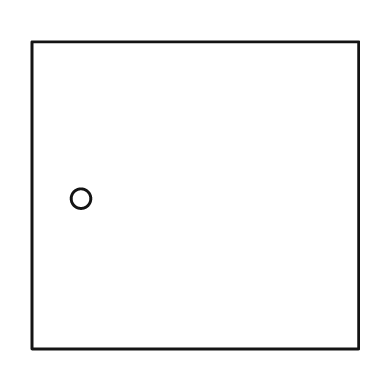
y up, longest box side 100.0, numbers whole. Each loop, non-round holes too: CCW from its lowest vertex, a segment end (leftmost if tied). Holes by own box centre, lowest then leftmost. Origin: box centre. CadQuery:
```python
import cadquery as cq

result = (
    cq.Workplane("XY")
    .moveTo(-50.0, -47.0)
    .lineTo(50.0, -47.0)
    .lineTo(50.0, 47.0)
    .lineTo(-50.0, 47.0)
    .close()
    .moveTo(-35.0, -1.0)
    .circle(3.0)
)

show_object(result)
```